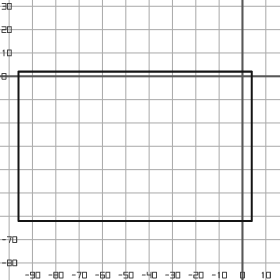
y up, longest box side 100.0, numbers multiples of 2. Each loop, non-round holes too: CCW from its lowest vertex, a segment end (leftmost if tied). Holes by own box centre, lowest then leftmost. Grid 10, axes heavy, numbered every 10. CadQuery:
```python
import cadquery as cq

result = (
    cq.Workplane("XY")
    .moveTo(-96.0, -62.0)
    .lineTo(4.0, -62.0)
    .lineTo(4.0, 2.0)
    .lineTo(-96.0, 2.0)
    .close()
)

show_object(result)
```